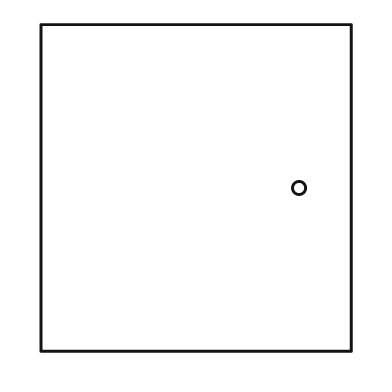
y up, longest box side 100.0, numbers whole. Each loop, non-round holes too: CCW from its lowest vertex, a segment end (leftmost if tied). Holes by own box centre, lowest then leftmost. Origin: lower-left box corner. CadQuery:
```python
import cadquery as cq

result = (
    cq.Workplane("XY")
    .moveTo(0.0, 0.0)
    .lineTo(95.0, 0.0)
    .lineTo(95.0, 100.0)
    .lineTo(0.0, 100.0)
    .close()
    .moveTo(79.0, 50.0)
    .circle(2.0)
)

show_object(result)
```